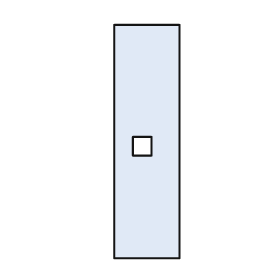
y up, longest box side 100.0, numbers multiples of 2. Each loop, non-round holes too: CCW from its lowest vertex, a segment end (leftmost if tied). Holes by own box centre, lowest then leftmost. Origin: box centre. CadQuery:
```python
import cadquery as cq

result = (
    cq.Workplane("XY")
    .moveTo(-14.0, -50.0)
    .lineTo(14.0, -50.0)
    .lineTo(14.0, 50.0)
    .lineTo(-14.0, 50.0)
    .close()
    .moveTo(-6.0, -6.0)
    .lineTo(2.0, -6.0)
    .lineTo(2.0, 2.0)
    .lineTo(-6.0, 2.0)
    .close()
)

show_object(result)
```